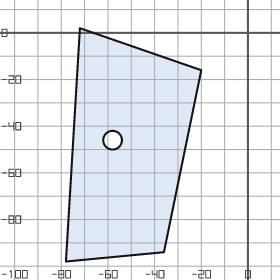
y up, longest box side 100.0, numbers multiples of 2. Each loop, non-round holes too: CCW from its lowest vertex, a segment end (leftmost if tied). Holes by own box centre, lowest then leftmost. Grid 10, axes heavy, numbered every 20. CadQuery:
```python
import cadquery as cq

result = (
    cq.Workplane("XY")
    .moveTo(-78.0, -98.0)
    .lineTo(-36.0, -94.0)
    .lineTo(-20.0, -16.0)
    .lineTo(-72.0, 2.0)
    .close()
    .moveTo(-58.0, -46.0)
    .circle(4.0)
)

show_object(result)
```